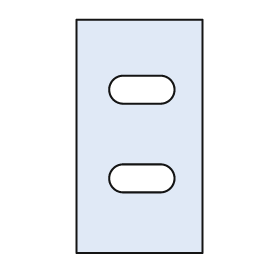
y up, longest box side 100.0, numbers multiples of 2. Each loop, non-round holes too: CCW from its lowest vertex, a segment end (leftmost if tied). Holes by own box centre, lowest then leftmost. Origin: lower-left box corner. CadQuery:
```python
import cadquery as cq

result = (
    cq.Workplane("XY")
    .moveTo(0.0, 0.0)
    .lineTo(54.0, 0.0)
    .lineTo(54.0, 100.0)
    .lineTo(0.0, 100.0)
    .close()
    .moveTo(20.0, 26.0)
    .lineTo(36.0, 26.0)
    .threePointArc((42.0, 32.0), (36.0, 38.0))
    .lineTo(20.0, 38.0)
    .threePointArc((14.0, 32.0), (20.0, 26.0))
    .close()
    .moveTo(20.0, 64.0)
    .lineTo(36.0, 64.0)
    .threePointArc((42.0, 70.0), (36.0, 76.0))
    .lineTo(20.0, 76.0)
    .threePointArc((14.0, 70.0), (20.0, 64.0))
    .close()
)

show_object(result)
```